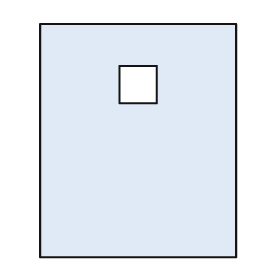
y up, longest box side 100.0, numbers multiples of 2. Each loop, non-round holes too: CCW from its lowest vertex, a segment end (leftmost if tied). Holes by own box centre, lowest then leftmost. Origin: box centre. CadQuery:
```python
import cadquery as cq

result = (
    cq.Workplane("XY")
    .moveTo(-42.0, -50.0)
    .lineTo(42.0, -50.0)
    .lineTo(42.0, 50.0)
    .lineTo(-42.0, 50.0)
    .close()
    .moveTo(-8.0, 16.0)
    .lineTo(8.0, 16.0)
    .lineTo(8.0, 32.0)
    .lineTo(-8.0, 32.0)
    .close()
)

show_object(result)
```